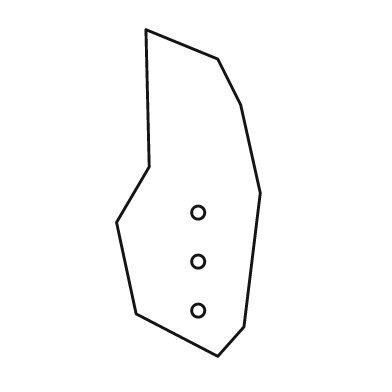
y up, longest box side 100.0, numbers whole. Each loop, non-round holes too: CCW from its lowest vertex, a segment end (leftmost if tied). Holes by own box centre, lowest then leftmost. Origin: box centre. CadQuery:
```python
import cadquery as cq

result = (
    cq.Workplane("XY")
    .moveTo(9.0, -50.0)
    .lineTo(17.0, -41.0)
    .lineTo(22.0, 0.0)
    .lineTo(16.0, 27.0)
    .lineTo(9.0, 41.0)
    .lineTo(-13.0, 50.0)
    .lineTo(-12.0, 8.0)
    .lineTo(-22.0, -9.0)
    .lineTo(-16.0, -37.0)
    .close()
    .moveTo(3.0, -36.0)
    .circle(2.0)
    .moveTo(3.0, -21.0)
    .circle(2.0)
    .moveTo(3.0, -6.0)
    .circle(2.0)
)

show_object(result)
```